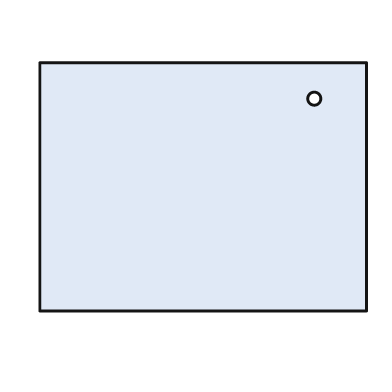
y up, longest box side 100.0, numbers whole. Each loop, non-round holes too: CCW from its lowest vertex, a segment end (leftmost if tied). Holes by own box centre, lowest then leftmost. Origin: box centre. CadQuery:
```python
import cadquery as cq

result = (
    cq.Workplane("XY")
    .moveTo(-50.0, -38.0)
    .lineTo(50.0, -38.0)
    .lineTo(50.0, 38.0)
    .lineTo(-50.0, 38.0)
    .close()
    .moveTo(34.0, 27.0)
    .circle(2.0)
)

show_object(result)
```